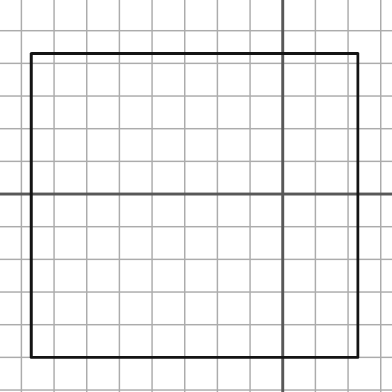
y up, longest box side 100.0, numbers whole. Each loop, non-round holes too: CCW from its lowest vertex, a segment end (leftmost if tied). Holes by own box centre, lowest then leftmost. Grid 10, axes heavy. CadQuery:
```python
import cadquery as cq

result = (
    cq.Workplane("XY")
    .moveTo(-77.0, -50.0)
    .lineTo(23.0, -50.0)
    .lineTo(23.0, 43.0)
    .lineTo(-77.0, 43.0)
    .close()
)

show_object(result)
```